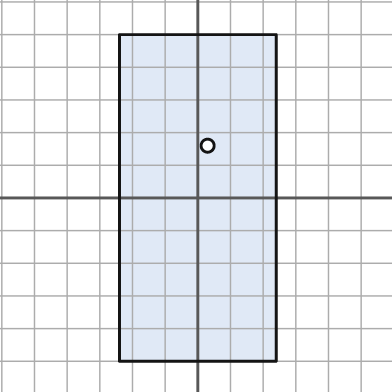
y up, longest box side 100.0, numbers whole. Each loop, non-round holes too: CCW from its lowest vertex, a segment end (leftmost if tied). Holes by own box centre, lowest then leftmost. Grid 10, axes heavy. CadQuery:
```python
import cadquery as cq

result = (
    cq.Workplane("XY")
    .moveTo(-24.0, -50.0)
    .lineTo(24.0, -50.0)
    .lineTo(24.0, 50.0)
    .lineTo(-24.0, 50.0)
    .close()
    .moveTo(3.0, 16.0)
    .circle(2.0)
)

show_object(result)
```